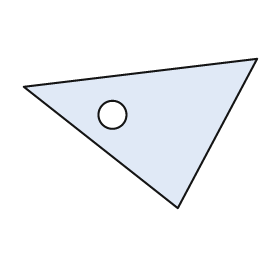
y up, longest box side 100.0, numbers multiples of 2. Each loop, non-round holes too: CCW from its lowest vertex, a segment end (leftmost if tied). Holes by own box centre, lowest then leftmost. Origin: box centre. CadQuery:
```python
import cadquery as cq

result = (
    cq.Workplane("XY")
    .moveTo(16.0, -32.0)
    .lineTo(50.0, 32.0)
    .lineTo(-50.0, 20.0)
    .close()
    .moveTo(-12.0, 8.0)
    .circle(6.0)
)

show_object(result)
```